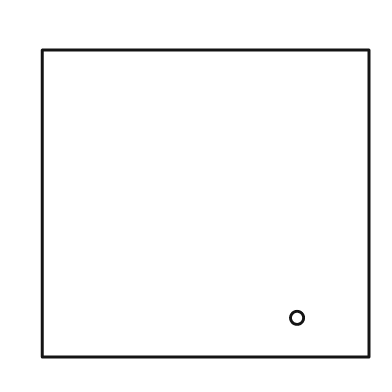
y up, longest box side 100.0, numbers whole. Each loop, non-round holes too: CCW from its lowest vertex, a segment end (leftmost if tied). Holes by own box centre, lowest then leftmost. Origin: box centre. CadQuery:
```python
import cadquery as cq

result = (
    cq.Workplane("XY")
    .moveTo(-50.0, -47.0)
    .lineTo(50.0, -47.0)
    .lineTo(50.0, 47.0)
    .lineTo(-50.0, 47.0)
    .close()
    .moveTo(28.0, -35.0)
    .circle(2.0)
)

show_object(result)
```